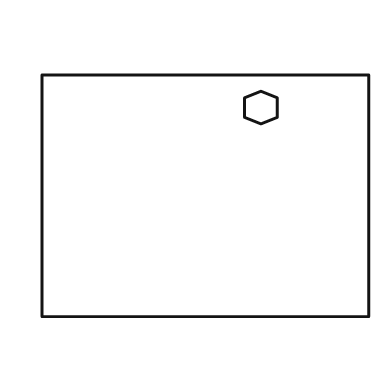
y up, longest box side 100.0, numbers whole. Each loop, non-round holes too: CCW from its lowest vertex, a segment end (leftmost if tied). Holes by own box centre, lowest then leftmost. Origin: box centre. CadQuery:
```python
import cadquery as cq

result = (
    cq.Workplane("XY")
    .moveTo(-50.0, -37.0)
    .lineTo(50.0, -37.0)
    .lineTo(50.0, 37.0)
    .lineTo(-50.0, 37.0)
    .close()
    .moveTo(17.0, 22.0)
    .lineTo(22.0, 24.0)
    .lineTo(22.0, 30.0)
    .lineTo(17.0, 32.0)
    .lineTo(12.0, 30.0)
    .lineTo(12.0, 24.0)
    .close()
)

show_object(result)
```